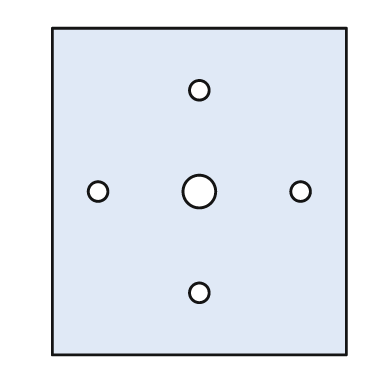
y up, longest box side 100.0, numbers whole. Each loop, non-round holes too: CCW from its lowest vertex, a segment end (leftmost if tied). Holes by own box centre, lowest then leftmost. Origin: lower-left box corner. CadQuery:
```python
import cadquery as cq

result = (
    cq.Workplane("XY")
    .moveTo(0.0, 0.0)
    .lineTo(90.0, 0.0)
    .lineTo(90.0, 100.0)
    .lineTo(0.0, 100.0)
    .close()
    .moveTo(45.0, 19.0)
    .circle(3.0)
    .moveTo(14.0, 50.0)
    .circle(3.0)
    .moveTo(45.0, 50.0)
    .circle(5.0)
    .moveTo(76.0, 50.0)
    .circle(3.0)
    .moveTo(45.0, 81.0)
    .circle(3.0)
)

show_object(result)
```